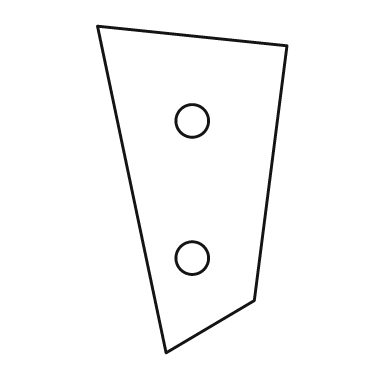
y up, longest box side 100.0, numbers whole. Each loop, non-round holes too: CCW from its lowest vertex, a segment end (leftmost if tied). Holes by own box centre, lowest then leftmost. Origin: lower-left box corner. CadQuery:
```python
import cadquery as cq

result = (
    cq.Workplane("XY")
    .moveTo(21.0, 0.0)
    .lineTo(48.0, 16.0)
    .lineTo(58.0, 94.0)
    .lineTo(0.0, 100.0)
    .close()
    .moveTo(29.0, 29.0)
    .circle(5.0)
    .moveTo(29.0, 71.0)
    .circle(5.0)
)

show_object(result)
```